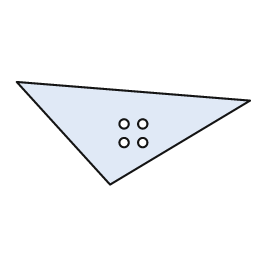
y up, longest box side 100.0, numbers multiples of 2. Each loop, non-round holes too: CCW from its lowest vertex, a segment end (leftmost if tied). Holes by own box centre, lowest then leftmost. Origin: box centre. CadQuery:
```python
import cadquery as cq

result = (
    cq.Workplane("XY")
    .moveTo(-10.0, -22.0)
    .lineTo(50.0, 14.0)
    .lineTo(-50.0, 22.0)
    .close()
    .moveTo(-4.0, -4.0)
    .circle(2.0)
    .moveTo(4.0, -4.0)
    .circle(2.0)
    .moveTo(-4.0, 4.0)
    .circle(2.0)
    .moveTo(4.0, 4.0)
    .circle(2.0)
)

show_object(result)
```